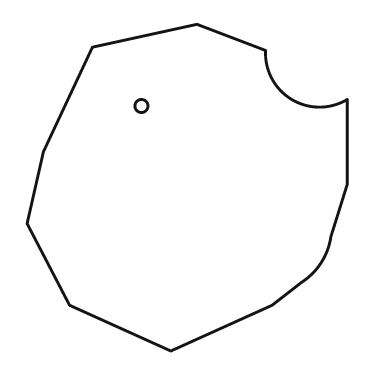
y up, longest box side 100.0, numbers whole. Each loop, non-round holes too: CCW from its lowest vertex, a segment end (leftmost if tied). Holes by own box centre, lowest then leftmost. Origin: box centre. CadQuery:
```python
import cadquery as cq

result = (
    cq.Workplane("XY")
    .moveTo(-5.0, -50.0)
    .lineTo(26.0, -36.0)
    .lineTo(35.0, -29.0)
    .threePointArc((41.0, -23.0), (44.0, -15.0))
    .lineTo(49.0, 1.0)
    .lineTo(49.0, 27.0)
    .threePointArc((32.0, 27.0), (24.0, 42.0))
    .lineTo(3.0, 50.0)
    .lineTo(-29.0, 43.0)
    .lineTo(-44.0, 11.0)
    .lineTo(-49.0, -11.0)
    .lineTo(-36.0, -36.0)
    .close()
    .moveTo(-14.0, 25.0)
    .circle(2.0)
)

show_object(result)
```